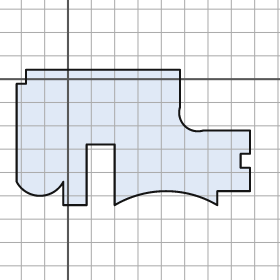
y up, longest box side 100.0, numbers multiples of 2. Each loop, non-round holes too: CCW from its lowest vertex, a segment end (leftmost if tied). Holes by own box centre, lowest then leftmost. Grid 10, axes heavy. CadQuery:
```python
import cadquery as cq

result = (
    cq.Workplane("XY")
    .moveTo(-2.0, -54.0)
    .lineTo(8.0, -54.0)
    .lineTo(8.0, -28.0)
    .lineTo(20.0, -28.0)
    .lineTo(20.0, -54.0)
    .threePointArc((42.0, -48.0), (64.0, -54.0))
    .lineTo(64.0, -48.0)
    .lineTo(78.0, -48.0)
    .lineTo(78.0, -38.0)
    .lineTo(74.0, -38.0)
    .lineTo(74.0, -32.0)
    .lineTo(78.0, -32.0)
    .lineTo(78.0, -22.0)
    .lineTo(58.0, -22.0)
    .threePointArc((50.0, -20.0), (48.0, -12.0))
    .lineTo(48.0, 4.0)
    .lineTo(-18.0, 4.0)
    .lineTo(-18.0, -2.0)
    .lineTo(-22.0, -2.0)
    .lineTo(-22.0, -44.0)
    .threePointArc((-12.0, -50.0), (-2.0, -44.0))
    .close()
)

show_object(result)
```